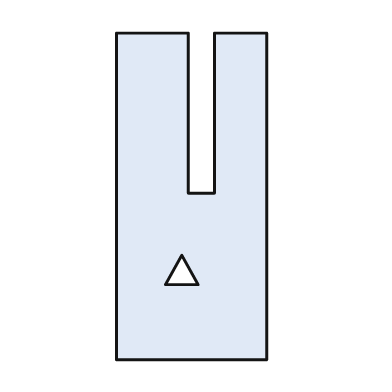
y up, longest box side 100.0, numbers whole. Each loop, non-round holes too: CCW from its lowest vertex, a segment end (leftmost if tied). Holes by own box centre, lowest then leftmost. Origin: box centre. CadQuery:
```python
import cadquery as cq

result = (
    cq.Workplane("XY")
    .moveTo(-23.0, -50.0)
    .lineTo(23.0, -50.0)
    .lineTo(23.0, 50.0)
    .lineTo(7.0, 50.0)
    .lineTo(7.0, 1.0)
    .lineTo(-1.0, 1.0)
    .lineTo(-1.0, 50.0)
    .lineTo(-23.0, 50.0)
    .close()
    .moveTo(-8.0, -27.0)
    .lineTo(2.0, -27.0)
    .lineTo(-3.0, -18.0)
    .close()
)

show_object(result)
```